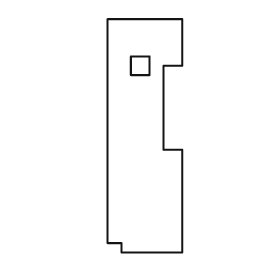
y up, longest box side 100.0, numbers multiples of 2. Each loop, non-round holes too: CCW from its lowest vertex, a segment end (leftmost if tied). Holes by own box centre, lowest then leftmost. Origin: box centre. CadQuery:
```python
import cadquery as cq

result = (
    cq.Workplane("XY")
    .moveTo(-10.0, -50.0)
    .lineTo(16.0, -50.0)
    .lineTo(16.0, -6.0)
    .lineTo(8.0, -6.0)
    .lineTo(8.0, 30.0)
    .lineTo(16.0, 30.0)
    .lineTo(16.0, 50.0)
    .lineTo(-16.0, 50.0)
    .lineTo(-16.0, -46.0)
    .lineTo(-10.0, -46.0)
    .close()
    .moveTo(-6.0, 26.0)
    .lineTo(2.0, 26.0)
    .lineTo(2.0, 34.0)
    .lineTo(-6.0, 34.0)
    .close()
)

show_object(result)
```